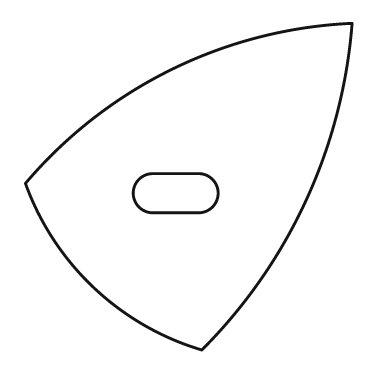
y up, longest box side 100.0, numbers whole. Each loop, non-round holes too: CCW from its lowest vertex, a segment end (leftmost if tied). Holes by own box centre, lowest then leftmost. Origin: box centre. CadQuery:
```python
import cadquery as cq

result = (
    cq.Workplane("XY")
    .moveTo(4.0, -50.0)
    .threePointArc((36.0, -4.0), (50.0, 50.0))
    .threePointArc((-5.0, 36.0), (-50.0, 1.0))
    .threePointArc((-29.0, -31.0), (4.0, -50.0))
    .close()
    .moveTo(-11.0, -8.0)
    .lineTo(3.0, -8.0)
    .threePointArc((9.0, -2.0), (3.0, 4.0))
    .lineTo(-11.0, 4.0)
    .threePointArc((-17.0, -2.0), (-11.0, -8.0))
    .close()
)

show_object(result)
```